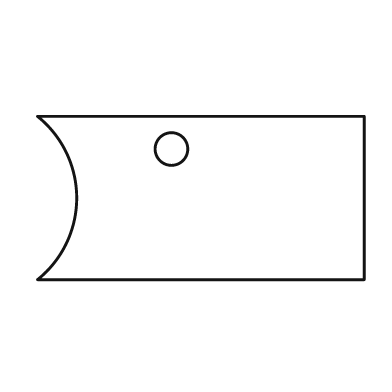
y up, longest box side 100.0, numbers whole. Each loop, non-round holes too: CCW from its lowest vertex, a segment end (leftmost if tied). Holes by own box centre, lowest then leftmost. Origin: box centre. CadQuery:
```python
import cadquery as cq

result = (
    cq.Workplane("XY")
    .moveTo(-50.0, -25.0)
    .lineTo(50.0, -25.0)
    .lineTo(50.0, 25.0)
    .lineTo(-50.0, 25.0)
    .threePointArc((-38.0, 0.0), (-50.0, -25.0))
    .close()
    .moveTo(-9.0, 15.0)
    .circle(5.0)
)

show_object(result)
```